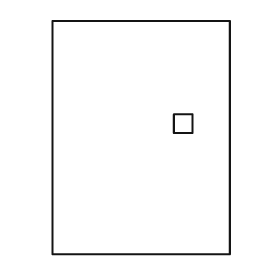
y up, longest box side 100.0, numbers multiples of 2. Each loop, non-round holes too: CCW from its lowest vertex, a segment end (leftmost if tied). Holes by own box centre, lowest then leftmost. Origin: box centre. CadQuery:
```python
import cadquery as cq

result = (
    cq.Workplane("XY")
    .moveTo(-38.0, -50.0)
    .lineTo(38.0, -50.0)
    .lineTo(38.0, 50.0)
    .lineTo(-38.0, 50.0)
    .close()
    .moveTo(14.0, 2.0)
    .lineTo(22.0, 2.0)
    .lineTo(22.0, 10.0)
    .lineTo(14.0, 10.0)
    .close()
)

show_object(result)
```